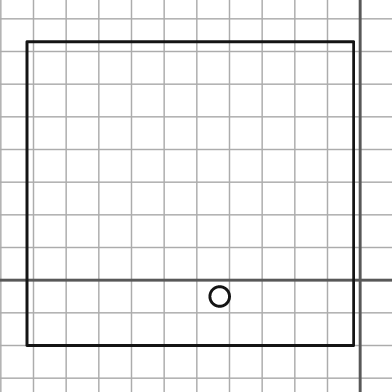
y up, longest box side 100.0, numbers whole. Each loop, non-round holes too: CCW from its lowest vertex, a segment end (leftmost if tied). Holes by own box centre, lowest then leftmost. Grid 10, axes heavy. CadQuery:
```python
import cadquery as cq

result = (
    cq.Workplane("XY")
    .moveTo(-102.0, -20.0)
    .lineTo(-2.0, -20.0)
    .lineTo(-2.0, 73.0)
    .lineTo(-102.0, 73.0)
    .close()
    .moveTo(-43.0, -5.0)
    .circle(3.0)
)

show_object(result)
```